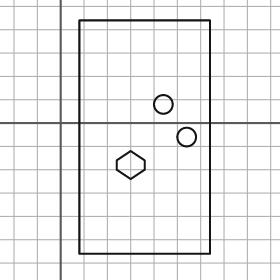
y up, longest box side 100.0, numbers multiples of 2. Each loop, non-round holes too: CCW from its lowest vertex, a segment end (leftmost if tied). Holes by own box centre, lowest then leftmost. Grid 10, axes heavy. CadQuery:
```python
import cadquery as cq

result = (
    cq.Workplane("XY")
    .moveTo(8.0, -56.0)
    .lineTo(64.0, -56.0)
    .lineTo(64.0, 44.0)
    .lineTo(8.0, 44.0)
    .close()
    .moveTo(30.0, -24.0)
    .lineTo(36.0, -20.0)
    .lineTo(36.0, -16.0)
    .lineTo(30.0, -12.0)
    .lineTo(24.0, -16.0)
    .lineTo(24.0, -20.0)
    .close()
    .moveTo(54.0, -6.0)
    .circle(4.0)
    .moveTo(44.0, 8.0)
    .circle(4.0)
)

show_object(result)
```